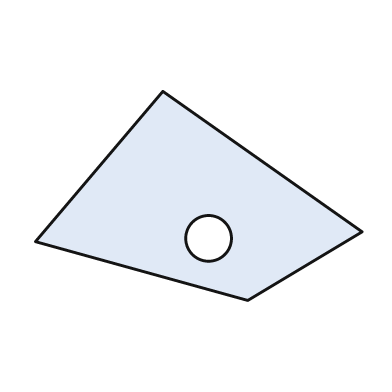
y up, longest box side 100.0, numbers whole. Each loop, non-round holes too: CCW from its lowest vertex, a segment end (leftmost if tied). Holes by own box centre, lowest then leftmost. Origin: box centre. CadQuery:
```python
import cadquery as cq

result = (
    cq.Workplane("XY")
    .moveTo(15.0, -32.0)
    .lineTo(50.0, -11.0)
    .lineTo(-11.0, 32.0)
    .lineTo(-50.0, -14.0)
    .close()
    .moveTo(3.0, -13.0)
    .circle(7.0)
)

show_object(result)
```